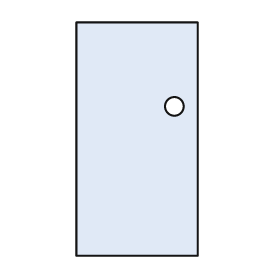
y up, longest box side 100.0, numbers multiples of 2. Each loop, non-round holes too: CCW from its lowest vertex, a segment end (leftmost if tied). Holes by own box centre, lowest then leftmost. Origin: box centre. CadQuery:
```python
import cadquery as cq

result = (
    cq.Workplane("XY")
    .moveTo(-26.0, -50.0)
    .lineTo(26.0, -50.0)
    .lineTo(26.0, 50.0)
    .lineTo(-26.0, 50.0)
    .close()
    .moveTo(16.0, 14.0)
    .circle(4.0)
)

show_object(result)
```